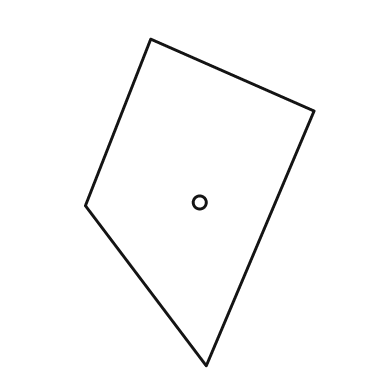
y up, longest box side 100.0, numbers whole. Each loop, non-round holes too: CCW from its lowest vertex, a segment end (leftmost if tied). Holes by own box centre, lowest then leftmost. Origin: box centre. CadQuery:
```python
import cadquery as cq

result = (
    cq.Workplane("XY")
    .moveTo(2.0, -50.0)
    .lineTo(35.0, 28.0)
    .lineTo(-15.0, 50.0)
    .lineTo(-35.0, -1.0)
    .close()
    .moveTo(0.0, 0.0)
    .circle(2.0)
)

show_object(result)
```